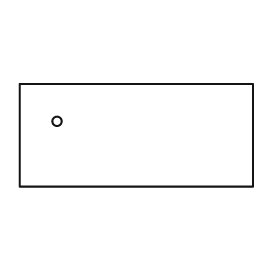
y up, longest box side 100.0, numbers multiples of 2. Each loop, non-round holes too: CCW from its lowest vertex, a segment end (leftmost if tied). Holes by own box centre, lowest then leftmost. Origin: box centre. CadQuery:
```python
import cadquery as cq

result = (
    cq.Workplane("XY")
    .moveTo(-50.0, -22.0)
    .lineTo(50.0, -22.0)
    .lineTo(50.0, 22.0)
    .lineTo(-50.0, 22.0)
    .close()
    .moveTo(-34.0, 6.0)
    .circle(2.0)
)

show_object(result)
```